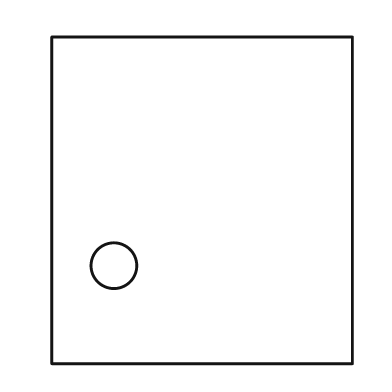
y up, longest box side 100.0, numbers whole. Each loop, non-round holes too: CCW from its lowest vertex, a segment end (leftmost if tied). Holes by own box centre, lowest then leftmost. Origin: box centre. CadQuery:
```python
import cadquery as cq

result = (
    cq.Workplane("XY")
    .moveTo(-46.0, -50.0)
    .lineTo(46.0, -50.0)
    .lineTo(46.0, 50.0)
    .lineTo(-46.0, 50.0)
    .close()
    .moveTo(-27.0, -20.0)
    .circle(7.0)
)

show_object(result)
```